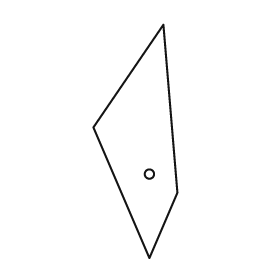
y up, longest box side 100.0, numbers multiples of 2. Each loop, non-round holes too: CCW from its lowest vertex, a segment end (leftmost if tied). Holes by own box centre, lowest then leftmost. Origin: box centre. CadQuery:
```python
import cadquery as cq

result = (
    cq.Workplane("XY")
    .moveTo(6.0, -50.0)
    .lineTo(18.0, -22.0)
    .lineTo(12.0, 50.0)
    .lineTo(-18.0, 6.0)
    .close()
    .moveTo(6.0, -14.0)
    .circle(2.0)
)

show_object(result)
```